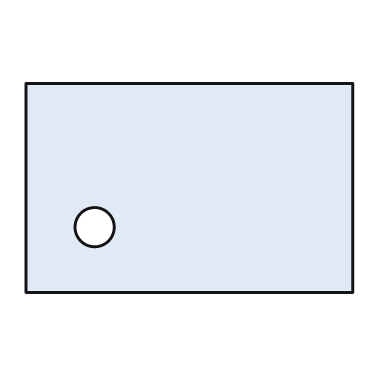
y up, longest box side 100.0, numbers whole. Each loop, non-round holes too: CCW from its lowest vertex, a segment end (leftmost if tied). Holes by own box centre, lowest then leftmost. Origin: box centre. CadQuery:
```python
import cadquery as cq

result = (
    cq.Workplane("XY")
    .moveTo(-50.0, -32.0)
    .lineTo(50.0, -32.0)
    .lineTo(50.0, 32.0)
    .lineTo(-50.0, 32.0)
    .close()
    .moveTo(-29.0, -12.0)
    .circle(6.0)
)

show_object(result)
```